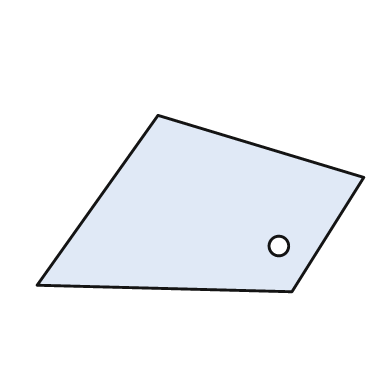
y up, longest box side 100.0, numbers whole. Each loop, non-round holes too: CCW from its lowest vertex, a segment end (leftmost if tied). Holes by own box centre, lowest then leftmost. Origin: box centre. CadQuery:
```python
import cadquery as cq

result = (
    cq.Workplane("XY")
    .moveTo(28.0, -27.0)
    .lineTo(50.0, 8.0)
    .lineTo(-13.0, 27.0)
    .lineTo(-50.0, -25.0)
    .close()
    .moveTo(24.0, -13.0)
    .circle(3.0)
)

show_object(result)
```